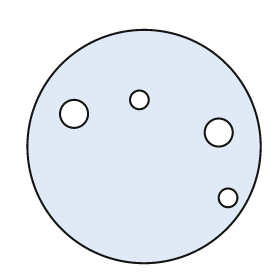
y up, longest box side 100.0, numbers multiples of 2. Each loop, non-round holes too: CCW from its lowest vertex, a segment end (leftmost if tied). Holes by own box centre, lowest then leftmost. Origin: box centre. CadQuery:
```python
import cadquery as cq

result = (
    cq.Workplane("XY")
    .moveTo(0.0, 0.0)
    .circle(50.0)
    .moveTo(36.0, -22.0)
    .circle(4.0)
    .moveTo(32.0, 6.0)
    .circle(6.0)
    .moveTo(-30.0, 14.0)
    .circle(6.0)
    .moveTo(-2.0, 20.0)
    .circle(4.0)
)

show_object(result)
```